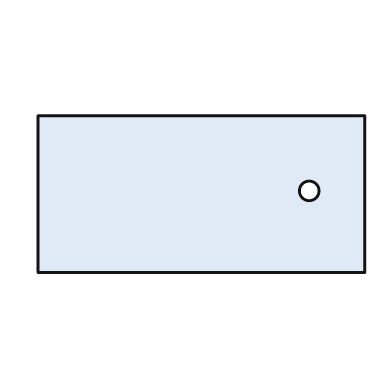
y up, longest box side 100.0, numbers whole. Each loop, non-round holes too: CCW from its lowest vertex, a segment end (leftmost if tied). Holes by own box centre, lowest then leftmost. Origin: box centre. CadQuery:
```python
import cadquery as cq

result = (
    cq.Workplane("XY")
    .moveTo(-50.0, -24.0)
    .lineTo(50.0, -24.0)
    .lineTo(50.0, 24.0)
    .lineTo(-50.0, 24.0)
    .close()
    .moveTo(33.0, 1.0)
    .circle(3.0)
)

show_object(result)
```